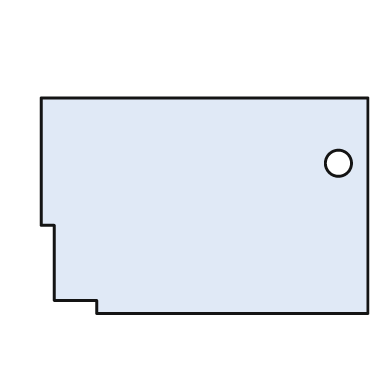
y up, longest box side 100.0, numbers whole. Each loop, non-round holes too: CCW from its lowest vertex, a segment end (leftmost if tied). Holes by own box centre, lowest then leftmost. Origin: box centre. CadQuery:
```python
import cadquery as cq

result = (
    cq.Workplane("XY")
    .moveTo(-33.0, -33.0)
    .lineTo(50.0, -33.0)
    .lineTo(50.0, 33.0)
    .lineTo(-50.0, 33.0)
    .lineTo(-50.0, -6.0)
    .lineTo(-46.0, -6.0)
    .lineTo(-46.0, -29.0)
    .lineTo(-33.0, -29.0)
    .close()
    .moveTo(41.0, 13.0)
    .circle(4.0)
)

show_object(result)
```